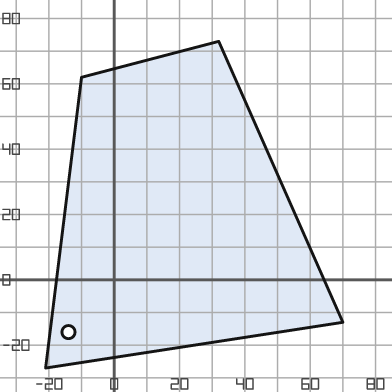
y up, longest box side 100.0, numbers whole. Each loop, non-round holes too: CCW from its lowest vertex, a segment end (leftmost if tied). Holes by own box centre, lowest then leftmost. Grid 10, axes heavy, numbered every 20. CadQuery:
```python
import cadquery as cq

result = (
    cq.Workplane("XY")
    .moveTo(-21.0, -27.0)
    .lineTo(70.0, -13.0)
    .lineTo(32.0, 73.0)
    .lineTo(-10.0, 62.0)
    .close()
    .moveTo(-14.0, -16.0)
    .circle(2.0)
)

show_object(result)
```